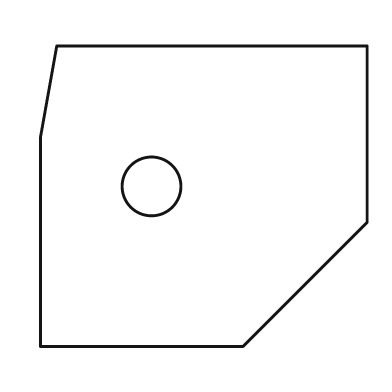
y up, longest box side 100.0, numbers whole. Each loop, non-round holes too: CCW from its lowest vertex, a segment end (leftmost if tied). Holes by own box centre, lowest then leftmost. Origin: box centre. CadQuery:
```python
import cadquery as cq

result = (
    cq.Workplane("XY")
    .moveTo(-50.0, -46.0)
    .lineTo(12.0, -46.0)
    .lineTo(50.0, -8.0)
    .lineTo(50.0, 46.0)
    .lineTo(-45.0, 46.0)
    .lineTo(-50.0, 18.0)
    .close()
    .moveTo(-16.0, 3.0)
    .circle(9.0)
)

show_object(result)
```